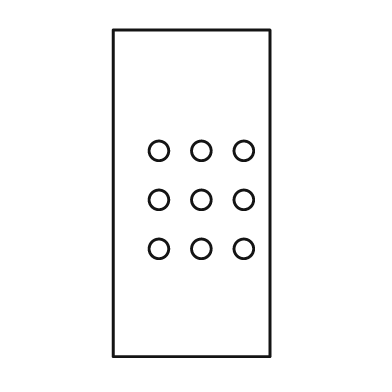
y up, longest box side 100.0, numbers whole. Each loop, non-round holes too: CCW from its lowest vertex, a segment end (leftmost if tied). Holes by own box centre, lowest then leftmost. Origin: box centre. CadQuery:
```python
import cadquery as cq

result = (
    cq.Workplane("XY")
    .moveTo(-24.0, -50.0)
    .lineTo(24.0, -50.0)
    .lineTo(24.0, 50.0)
    .lineTo(-24.0, 50.0)
    .close()
    .moveTo(-10.0, -17.0)
    .circle(3.0)
    .moveTo(3.0, -17.0)
    .circle(3.0)
    .moveTo(16.0, -17.0)
    .circle(3.0)
    .moveTo(-10.0, -2.0)
    .circle(3.0)
    .moveTo(3.0, -2.0)
    .circle(3.0)
    .moveTo(16.0, -2.0)
    .circle(3.0)
    .moveTo(-10.0, 13.0)
    .circle(3.0)
    .moveTo(3.0, 13.0)
    .circle(3.0)
    .moveTo(16.0, 13.0)
    .circle(3.0)
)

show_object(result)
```